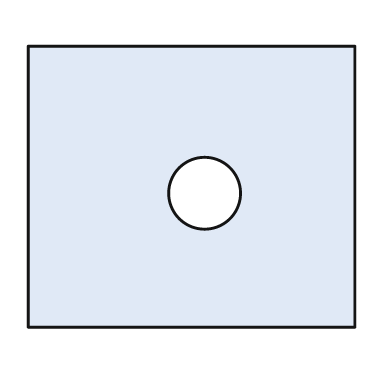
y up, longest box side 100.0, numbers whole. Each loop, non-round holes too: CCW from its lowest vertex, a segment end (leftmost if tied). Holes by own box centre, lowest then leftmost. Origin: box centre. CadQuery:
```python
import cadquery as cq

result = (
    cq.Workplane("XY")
    .moveTo(-50.0, -43.0)
    .lineTo(50.0, -43.0)
    .lineTo(50.0, 43.0)
    .lineTo(-50.0, 43.0)
    .close()
    .moveTo(4.0, -2.0)
    .circle(11.0)
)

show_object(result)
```